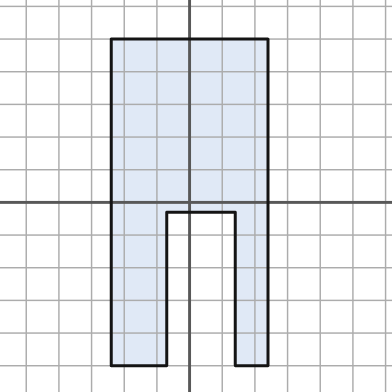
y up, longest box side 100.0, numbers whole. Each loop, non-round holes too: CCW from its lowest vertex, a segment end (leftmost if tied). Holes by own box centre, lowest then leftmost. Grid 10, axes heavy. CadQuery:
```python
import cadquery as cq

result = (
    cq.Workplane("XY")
    .moveTo(-24.0, -50.0)
    .lineTo(-7.0, -50.0)
    .lineTo(-7.0, -3.0)
    .lineTo(14.0, -3.0)
    .lineTo(14.0, -50.0)
    .lineTo(24.0, -50.0)
    .lineTo(24.0, 50.0)
    .lineTo(-24.0, 50.0)
    .close()
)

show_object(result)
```